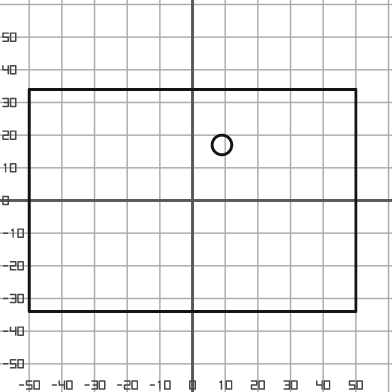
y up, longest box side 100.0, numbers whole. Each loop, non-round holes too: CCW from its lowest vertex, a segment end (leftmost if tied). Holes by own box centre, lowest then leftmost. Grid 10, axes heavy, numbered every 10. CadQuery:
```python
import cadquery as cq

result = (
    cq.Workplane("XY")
    .moveTo(-50.0, -34.0)
    .lineTo(50.0, -34.0)
    .lineTo(50.0, 34.0)
    .lineTo(-50.0, 34.0)
    .close()
    .moveTo(9.0, 17.0)
    .circle(3.0)
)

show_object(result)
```